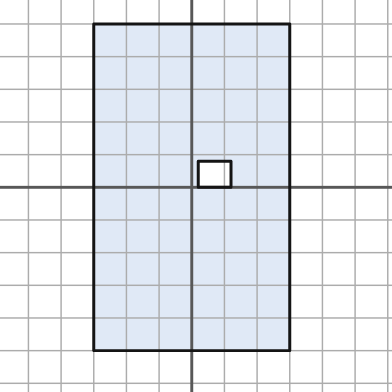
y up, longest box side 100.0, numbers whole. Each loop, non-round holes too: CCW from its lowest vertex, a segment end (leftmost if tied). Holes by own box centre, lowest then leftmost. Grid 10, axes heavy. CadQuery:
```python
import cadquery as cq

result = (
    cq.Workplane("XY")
    .moveTo(-30.0, -50.0)
    .lineTo(30.0, -50.0)
    .lineTo(30.0, 50.0)
    .lineTo(-30.0, 50.0)
    .close()
    .moveTo(2.0, 0.0)
    .lineTo(12.0, 0.0)
    .lineTo(12.0, 8.0)
    .lineTo(2.0, 8.0)
    .close()
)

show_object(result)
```